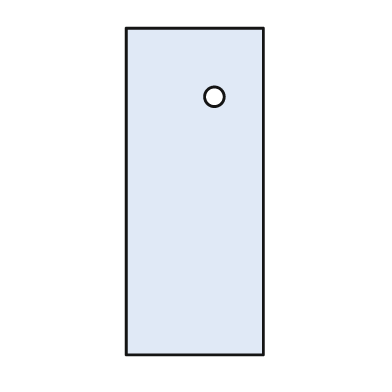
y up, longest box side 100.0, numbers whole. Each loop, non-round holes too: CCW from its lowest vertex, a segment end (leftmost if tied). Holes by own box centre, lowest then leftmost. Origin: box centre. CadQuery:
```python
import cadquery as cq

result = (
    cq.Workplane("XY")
    .moveTo(-21.0, -50.0)
    .lineTo(21.0, -50.0)
    .lineTo(21.0, 50.0)
    .lineTo(-21.0, 50.0)
    .close()
    .moveTo(6.0, 29.0)
    .circle(3.0)
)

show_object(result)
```